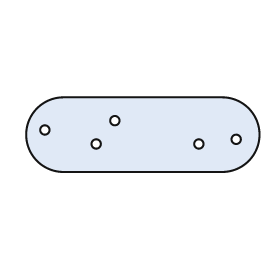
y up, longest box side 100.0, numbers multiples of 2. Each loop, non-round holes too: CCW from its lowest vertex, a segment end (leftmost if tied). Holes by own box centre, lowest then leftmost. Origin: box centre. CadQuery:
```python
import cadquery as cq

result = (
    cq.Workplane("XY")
    .moveTo(-34.0, -16.0)
    .lineTo(34.0, -16.0)
    .threePointArc((50.0, 0.0), (34.0, 16.0))
    .lineTo(-34.0, 16.0)
    .threePointArc((-50.0, 0.0), (-34.0, -16.0))
    .close()
    .moveTo(-20.0, -4.0)
    .circle(2.0)
    .moveTo(24.0, -4.0)
    .circle(2.0)
    .moveTo(40.0, -2.0)
    .circle(2.0)
    .moveTo(-42.0, 2.0)
    .circle(2.0)
    .moveTo(-12.0, 6.0)
    .circle(2.0)
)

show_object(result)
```